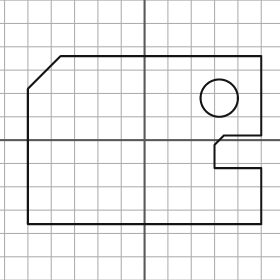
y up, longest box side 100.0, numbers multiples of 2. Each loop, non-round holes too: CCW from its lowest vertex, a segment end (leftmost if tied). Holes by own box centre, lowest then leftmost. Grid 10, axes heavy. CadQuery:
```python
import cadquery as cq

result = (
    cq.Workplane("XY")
    .moveTo(-50.0, -36.0)
    .lineTo(50.0, -36.0)
    .lineTo(50.0, -12.0)
    .lineTo(30.0, -12.0)
    .lineTo(30.0, -2.0)
    .lineTo(34.0, 2.0)
    .lineTo(50.0, 2.0)
    .lineTo(50.0, 36.0)
    .lineTo(-36.0, 36.0)
    .lineTo(-50.0, 22.0)
    .close()
    .moveTo(32.0, 18.0)
    .circle(8.0)
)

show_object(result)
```